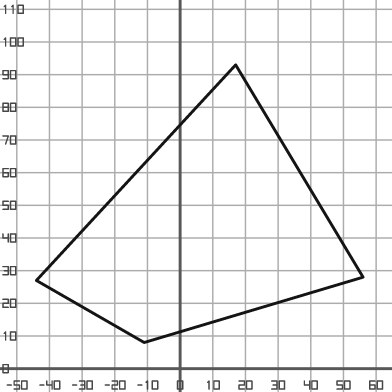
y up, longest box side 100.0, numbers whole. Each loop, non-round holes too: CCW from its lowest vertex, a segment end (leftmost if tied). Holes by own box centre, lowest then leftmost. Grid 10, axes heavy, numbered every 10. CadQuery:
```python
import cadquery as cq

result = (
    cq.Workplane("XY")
    .moveTo(-11.0, 8.0)
    .lineTo(56.0, 28.0)
    .lineTo(17.0, 93.0)
    .lineTo(-44.0, 27.0)
    .close()
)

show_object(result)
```